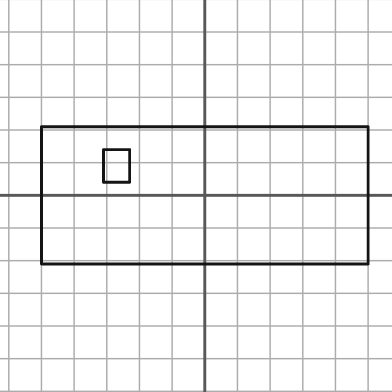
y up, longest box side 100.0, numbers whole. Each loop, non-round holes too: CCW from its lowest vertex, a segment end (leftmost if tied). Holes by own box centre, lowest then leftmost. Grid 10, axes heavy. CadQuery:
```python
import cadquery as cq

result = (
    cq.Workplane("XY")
    .moveTo(-50.0, -21.0)
    .lineTo(50.0, -21.0)
    .lineTo(50.0, 21.0)
    .lineTo(-50.0, 21.0)
    .close()
    .moveTo(-31.0, 4.0)
    .lineTo(-23.0, 4.0)
    .lineTo(-23.0, 14.0)
    .lineTo(-31.0, 14.0)
    .close()
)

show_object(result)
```